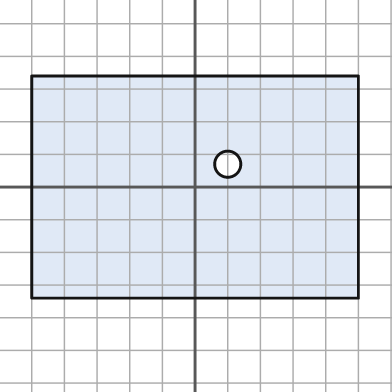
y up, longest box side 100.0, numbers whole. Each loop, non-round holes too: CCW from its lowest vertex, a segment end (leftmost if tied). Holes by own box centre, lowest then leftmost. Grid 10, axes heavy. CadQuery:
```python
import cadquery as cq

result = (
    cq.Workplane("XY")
    .moveTo(-50.0, -34.0)
    .lineTo(50.0, -34.0)
    .lineTo(50.0, 34.0)
    .lineTo(-50.0, 34.0)
    .close()
    .moveTo(10.0, 7.0)
    .circle(4.0)
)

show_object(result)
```